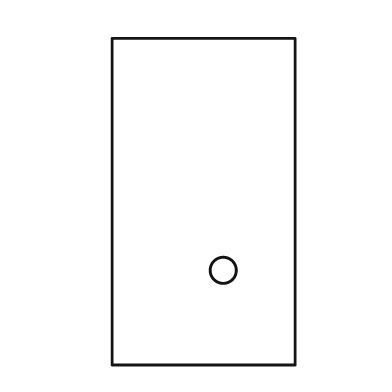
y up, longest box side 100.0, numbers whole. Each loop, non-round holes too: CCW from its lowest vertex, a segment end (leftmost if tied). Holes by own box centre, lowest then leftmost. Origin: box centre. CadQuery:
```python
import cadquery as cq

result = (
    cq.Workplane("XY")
    .moveTo(-28.0, -50.0)
    .lineTo(28.0, -50.0)
    .lineTo(28.0, 50.0)
    .lineTo(-28.0, 50.0)
    .close()
    .moveTo(6.0, -21.0)
    .circle(4.0)
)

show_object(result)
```